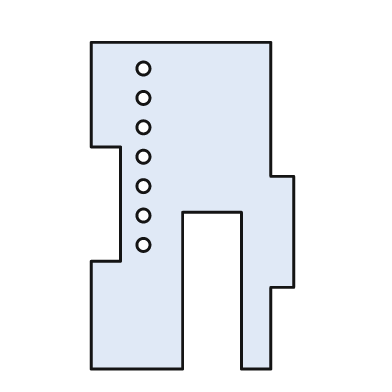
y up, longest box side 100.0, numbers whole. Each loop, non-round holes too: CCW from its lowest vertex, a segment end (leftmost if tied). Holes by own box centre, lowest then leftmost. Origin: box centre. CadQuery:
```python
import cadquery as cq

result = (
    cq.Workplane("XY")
    .moveTo(-31.0, -50.0)
    .lineTo(-3.0, -50.0)
    .lineTo(-3.0, -2.0)
    .lineTo(15.0, -2.0)
    .lineTo(15.0, -50.0)
    .lineTo(24.0, -50.0)
    .lineTo(24.0, -25.0)
    .lineTo(31.0, -25.0)
    .lineTo(31.0, 9.0)
    .lineTo(24.0, 9.0)
    .lineTo(24.0, 50.0)
    .lineTo(-31.0, 50.0)
    .lineTo(-31.0, 18.0)
    .lineTo(-22.0, 18.0)
    .lineTo(-22.0, -17.0)
    .lineTo(-31.0, -17.0)
    .close()
    .moveTo(-15.0, -12.0)
    .circle(2.0)
    .moveTo(-15.0, -3.0)
    .circle(2.0)
    .moveTo(-15.0, 6.0)
    .circle(2.0)
    .moveTo(-15.0, 15.0)
    .circle(2.0)
    .moveTo(-15.0, 24.0)
    .circle(2.0)
    .moveTo(-15.0, 33.0)
    .circle(2.0)
    .moveTo(-15.0, 42.0)
    .circle(2.0)
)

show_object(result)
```